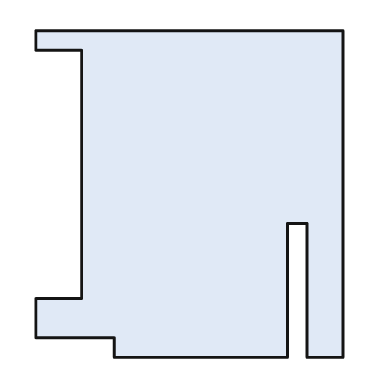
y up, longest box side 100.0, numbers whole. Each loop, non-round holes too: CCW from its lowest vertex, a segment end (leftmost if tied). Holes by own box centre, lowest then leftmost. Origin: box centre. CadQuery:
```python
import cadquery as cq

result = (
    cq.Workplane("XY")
    .moveTo(-23.0, -50.0)
    .lineTo(30.0, -50.0)
    .lineTo(30.0, -9.0)
    .lineTo(36.0, -9.0)
    .lineTo(36.0, -50.0)
    .lineTo(47.0, -50.0)
    .lineTo(47.0, 50.0)
    .lineTo(-47.0, 50.0)
    .lineTo(-47.0, 44.0)
    .lineTo(-33.0, 44.0)
    .lineTo(-33.0, -32.0)
    .lineTo(-47.0, -32.0)
    .lineTo(-47.0, -44.0)
    .lineTo(-23.0, -44.0)
    .close()
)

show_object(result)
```